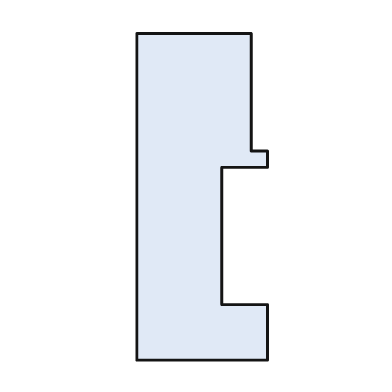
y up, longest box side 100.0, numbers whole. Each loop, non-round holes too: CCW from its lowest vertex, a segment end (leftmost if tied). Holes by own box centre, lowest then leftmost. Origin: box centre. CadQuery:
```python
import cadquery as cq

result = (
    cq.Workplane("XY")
    .moveTo(-20.0, -50.0)
    .lineTo(20.0, -50.0)
    .lineTo(20.0, -33.0)
    .lineTo(6.0, -33.0)
    .lineTo(6.0, 9.0)
    .lineTo(20.0, 9.0)
    .lineTo(20.0, 14.0)
    .lineTo(15.0, 14.0)
    .lineTo(15.0, 50.0)
    .lineTo(-20.0, 50.0)
    .close()
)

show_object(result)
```